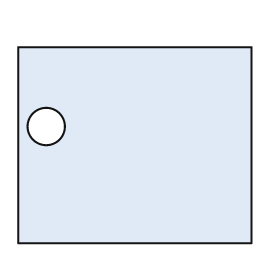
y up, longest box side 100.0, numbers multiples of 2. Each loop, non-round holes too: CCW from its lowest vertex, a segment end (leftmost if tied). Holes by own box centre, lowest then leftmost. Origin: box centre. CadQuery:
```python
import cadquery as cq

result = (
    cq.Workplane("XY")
    .moveTo(-50.0, -42.0)
    .lineTo(50.0, -42.0)
    .lineTo(50.0, 42.0)
    .lineTo(-50.0, 42.0)
    .close()
    .moveTo(-38.0, 8.0)
    .circle(8.0)
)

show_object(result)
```